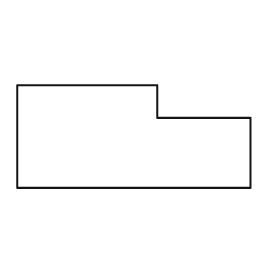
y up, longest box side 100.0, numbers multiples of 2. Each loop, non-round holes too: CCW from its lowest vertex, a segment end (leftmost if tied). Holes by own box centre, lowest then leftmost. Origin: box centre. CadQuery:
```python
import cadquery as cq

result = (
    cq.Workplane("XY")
    .moveTo(-50.0, -22.0)
    .lineTo(50.0, -22.0)
    .lineTo(50.0, 8.0)
    .lineTo(10.0, 8.0)
    .lineTo(10.0, 22.0)
    .lineTo(-50.0, 22.0)
    .close()
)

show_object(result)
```